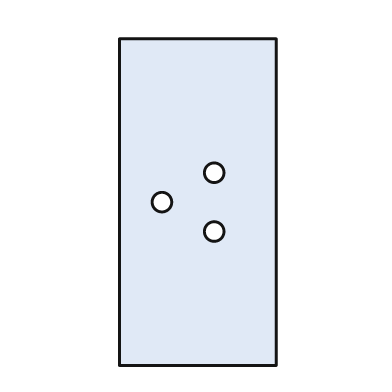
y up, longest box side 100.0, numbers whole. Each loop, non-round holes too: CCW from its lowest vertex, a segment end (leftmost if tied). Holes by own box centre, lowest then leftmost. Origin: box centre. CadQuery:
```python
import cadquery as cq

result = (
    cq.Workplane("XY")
    .moveTo(-24.0, -50.0)
    .lineTo(24.0, -50.0)
    .lineTo(24.0, 50.0)
    .lineTo(-24.0, 50.0)
    .close()
    .moveTo(5.0, -9.0)
    .circle(3.0)
    .moveTo(-11.0, 0.0)
    .circle(3.0)
    .moveTo(5.0, 9.0)
    .circle(3.0)
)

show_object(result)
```